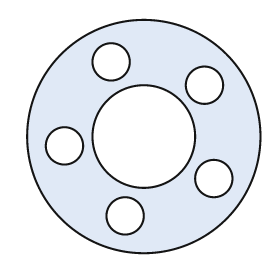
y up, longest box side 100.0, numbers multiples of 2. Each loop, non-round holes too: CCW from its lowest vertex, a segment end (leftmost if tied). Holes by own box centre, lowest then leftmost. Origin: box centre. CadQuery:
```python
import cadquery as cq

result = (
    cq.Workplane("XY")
    .moveTo(0.0, 0.0)
    .circle(50.0)
    .moveTo(-8.0, -34.0)
    .circle(8.0)
    .moveTo(30.0, -18.0)
    .circle(8.0)
    .moveTo(-34.0, -4.0)
    .circle(8.0)
    .moveTo(0.0, 0.0)
    .circle(22.0)
    .moveTo(26.0, 22.0)
    .circle(8.0)
    .moveTo(-14.0, 32.0)
    .circle(8.0)
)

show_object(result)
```